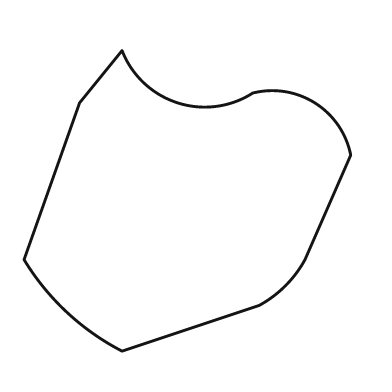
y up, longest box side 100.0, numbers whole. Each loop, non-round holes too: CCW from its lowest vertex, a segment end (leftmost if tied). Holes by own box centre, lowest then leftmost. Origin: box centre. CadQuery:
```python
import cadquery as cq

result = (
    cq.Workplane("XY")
    .moveTo(-20.0, -46.0)
    .lineTo(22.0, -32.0)
    .threePointArc((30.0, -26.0), (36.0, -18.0))
    .lineTo(50.0, 14.0)
    .threePointArc((39.0, 30.0), (20.0, 33.0))
    .threePointArc((-3.0, 30.0), (-20.0, 46.0))
    .lineTo(-33.0, 30.0)
    .lineTo(-50.0, -18.0)
    .threePointArc((-37.0, -34.0), (-20.0, -46.0))
    .close()
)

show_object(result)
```